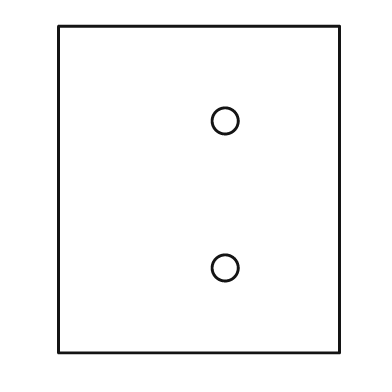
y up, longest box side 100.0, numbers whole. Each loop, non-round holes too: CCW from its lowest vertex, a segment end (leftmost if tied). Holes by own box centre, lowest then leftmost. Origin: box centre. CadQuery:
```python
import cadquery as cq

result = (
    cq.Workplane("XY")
    .moveTo(-43.0, -50.0)
    .lineTo(43.0, -50.0)
    .lineTo(43.0, 50.0)
    .lineTo(-43.0, 50.0)
    .close()
    .moveTo(8.0, -24.0)
    .circle(4.0)
    .moveTo(8.0, 21.0)
    .circle(4.0)
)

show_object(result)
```